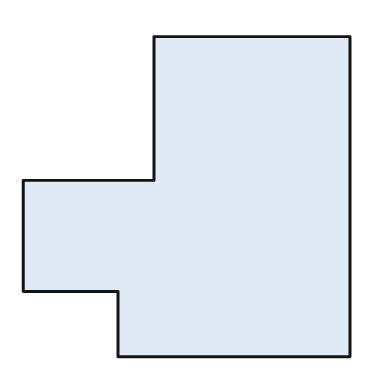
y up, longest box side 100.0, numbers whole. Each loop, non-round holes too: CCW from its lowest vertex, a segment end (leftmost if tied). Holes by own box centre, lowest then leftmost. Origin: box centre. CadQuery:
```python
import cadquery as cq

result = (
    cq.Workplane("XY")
    .moveTo(-21.0, -49.0)
    .lineTo(50.0, -49.0)
    .lineTo(50.0, 49.0)
    .lineTo(-10.0, 49.0)
    .lineTo(-10.0, 5.0)
    .lineTo(-50.0, 5.0)
    .lineTo(-50.0, -29.0)
    .lineTo(-21.0, -29.0)
    .close()
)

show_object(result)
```